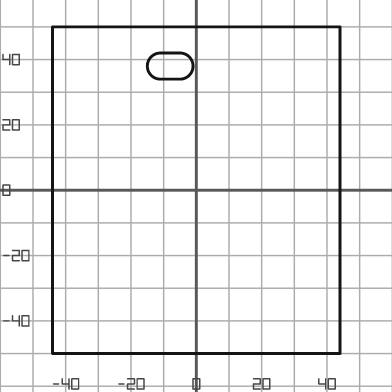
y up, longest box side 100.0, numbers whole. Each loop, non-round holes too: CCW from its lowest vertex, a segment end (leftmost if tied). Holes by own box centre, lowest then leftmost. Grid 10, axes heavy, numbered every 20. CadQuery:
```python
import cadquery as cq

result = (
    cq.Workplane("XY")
    .moveTo(-44.0, -50.0)
    .lineTo(44.0, -50.0)
    .lineTo(44.0, 50.0)
    .lineTo(-44.0, 50.0)
    .close()
    .moveTo(-11.0, 34.0)
    .lineTo(-5.0, 34.0)
    .threePointArc((-1.0, 38.0), (-5.0, 42.0))
    .lineTo(-11.0, 42.0)
    .threePointArc((-15.0, 38.0), (-11.0, 34.0))
    .close()
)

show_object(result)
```